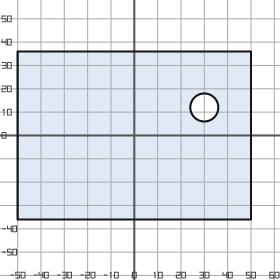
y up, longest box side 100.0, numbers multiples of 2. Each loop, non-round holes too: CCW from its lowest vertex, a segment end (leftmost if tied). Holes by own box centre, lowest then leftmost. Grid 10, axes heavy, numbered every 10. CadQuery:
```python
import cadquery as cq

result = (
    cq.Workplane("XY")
    .moveTo(-50.0, -36.0)
    .lineTo(50.0, -36.0)
    .lineTo(50.0, 36.0)
    .lineTo(-50.0, 36.0)
    .close()
    .moveTo(30.0, 12.0)
    .circle(6.0)
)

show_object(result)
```